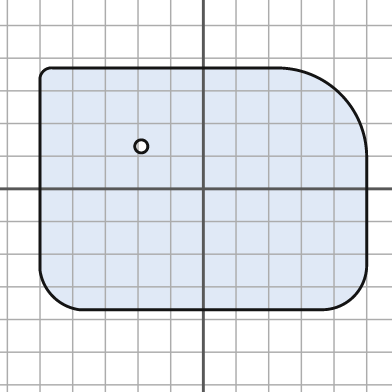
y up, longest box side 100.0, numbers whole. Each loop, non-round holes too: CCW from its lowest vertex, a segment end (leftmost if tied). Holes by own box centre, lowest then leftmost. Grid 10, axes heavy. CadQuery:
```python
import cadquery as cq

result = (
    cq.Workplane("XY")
    .moveTo(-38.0, -37.0)
    .lineTo(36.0, -37.0)
    .threePointArc((46.0, -33.0), (50.0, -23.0))
    .lineTo(50.0, 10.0)
    .threePointArc((42.0, 29.0), (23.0, 37.0))
    .lineTo(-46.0, 37.0)
    .threePointArc((-49.0, 36.0), (-50.0, 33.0))
    .lineTo(-50.0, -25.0)
    .threePointArc((-46.0, -33.0), (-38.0, -37.0))
    .close()
    .moveTo(-19.0, 13.0)
    .circle(2.0)
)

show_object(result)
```